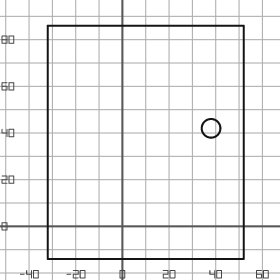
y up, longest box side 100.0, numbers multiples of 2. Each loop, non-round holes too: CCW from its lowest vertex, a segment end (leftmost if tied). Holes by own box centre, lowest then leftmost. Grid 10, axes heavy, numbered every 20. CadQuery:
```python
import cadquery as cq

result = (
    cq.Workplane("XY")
    .moveTo(-32.0, -14.0)
    .lineTo(52.0, -14.0)
    .lineTo(52.0, 86.0)
    .lineTo(-32.0, 86.0)
    .close()
    .moveTo(38.0, 42.0)
    .circle(4.0)
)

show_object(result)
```